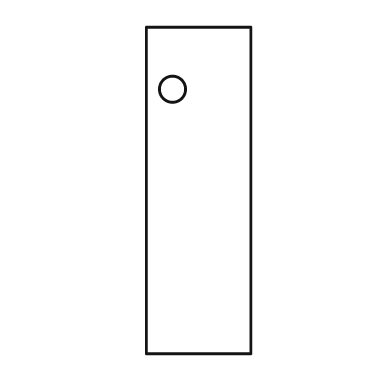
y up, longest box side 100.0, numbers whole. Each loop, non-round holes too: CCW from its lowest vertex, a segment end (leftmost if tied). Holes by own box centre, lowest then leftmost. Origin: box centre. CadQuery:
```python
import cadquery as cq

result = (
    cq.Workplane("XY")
    .moveTo(-16.0, -50.0)
    .lineTo(16.0, -50.0)
    .lineTo(16.0, 50.0)
    .lineTo(-16.0, 50.0)
    .close()
    .moveTo(-8.0, 31.0)
    .circle(4.0)
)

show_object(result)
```